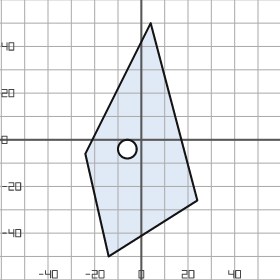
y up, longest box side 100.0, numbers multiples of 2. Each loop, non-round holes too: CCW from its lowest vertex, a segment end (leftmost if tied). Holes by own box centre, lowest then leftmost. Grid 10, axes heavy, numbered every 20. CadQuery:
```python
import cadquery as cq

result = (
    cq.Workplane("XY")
    .moveTo(-14.0, -50.0)
    .lineTo(24.0, -26.0)
    .lineTo(4.0, 50.0)
    .lineTo(-24.0, -6.0)
    .close()
    .moveTo(-6.0, -4.0)
    .circle(4.0)
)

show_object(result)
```